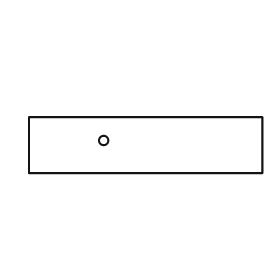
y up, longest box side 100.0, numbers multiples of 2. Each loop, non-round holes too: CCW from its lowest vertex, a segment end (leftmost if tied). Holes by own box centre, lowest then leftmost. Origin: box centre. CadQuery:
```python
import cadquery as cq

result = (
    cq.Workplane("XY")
    .moveTo(-50.0, -12.0)
    .lineTo(50.0, -12.0)
    .lineTo(50.0, 12.0)
    .lineTo(-50.0, 12.0)
    .close()
    .moveTo(-18.0, 2.0)
    .circle(2.0)
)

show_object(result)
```